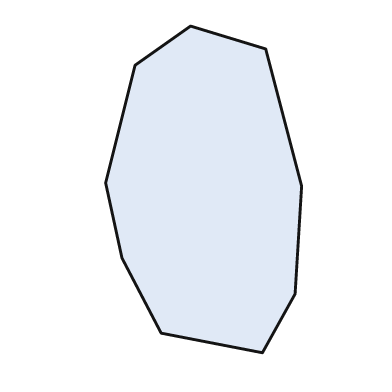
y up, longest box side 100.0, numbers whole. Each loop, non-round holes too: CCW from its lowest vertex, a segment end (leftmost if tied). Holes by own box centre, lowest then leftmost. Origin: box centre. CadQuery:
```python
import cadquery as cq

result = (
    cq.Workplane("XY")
    .moveTo(18.0, -50.0)
    .lineTo(28.0, -32.0)
    .lineTo(30.0, 1.0)
    .lineTo(19.0, 43.0)
    .lineTo(-4.0, 50.0)
    .lineTo(-21.0, 38.0)
    .lineTo(-30.0, 2.0)
    .lineTo(-25.0, -21.0)
    .lineTo(-13.0, -44.0)
    .close()
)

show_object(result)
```